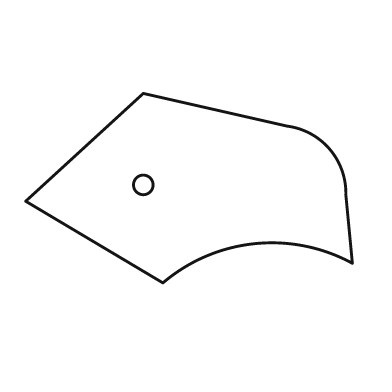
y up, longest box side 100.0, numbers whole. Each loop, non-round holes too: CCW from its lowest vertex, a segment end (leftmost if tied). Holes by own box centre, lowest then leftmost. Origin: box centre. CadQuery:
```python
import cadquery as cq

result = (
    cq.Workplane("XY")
    .moveTo(-8.0, -29.0)
    .threePointArc((20.0, -17.0), (50.0, -23.0))
    .lineTo(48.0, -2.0)
    .threePointArc((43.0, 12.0), (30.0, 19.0))
    .lineTo(-14.0, 29.0)
    .lineTo(-50.0, -4.0)
    .close()
    .moveTo(-14.0, 1.0)
    .circle(3.0)
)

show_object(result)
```